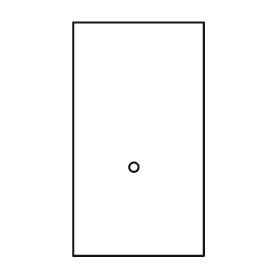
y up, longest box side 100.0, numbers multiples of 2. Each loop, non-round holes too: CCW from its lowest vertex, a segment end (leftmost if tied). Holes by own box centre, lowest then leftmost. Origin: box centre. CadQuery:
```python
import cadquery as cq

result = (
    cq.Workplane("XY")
    .moveTo(-28.0, -50.0)
    .lineTo(28.0, -50.0)
    .lineTo(28.0, 50.0)
    .lineTo(-28.0, 50.0)
    .close()
    .moveTo(-2.0, -12.0)
    .circle(2.0)
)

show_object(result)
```